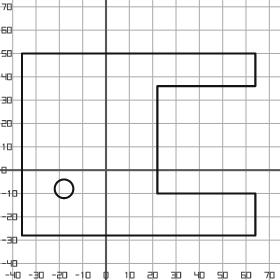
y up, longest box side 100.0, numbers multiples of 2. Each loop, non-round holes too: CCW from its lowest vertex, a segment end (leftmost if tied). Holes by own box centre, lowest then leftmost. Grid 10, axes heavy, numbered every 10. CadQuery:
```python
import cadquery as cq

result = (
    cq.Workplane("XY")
    .moveTo(-36.0, -28.0)
    .lineTo(64.0, -28.0)
    .lineTo(64.0, -10.0)
    .lineTo(22.0, -10.0)
    .lineTo(22.0, 36.0)
    .lineTo(64.0, 36.0)
    .lineTo(64.0, 50.0)
    .lineTo(-36.0, 50.0)
    .close()
    .moveTo(-18.0, -8.0)
    .circle(4.0)
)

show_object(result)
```